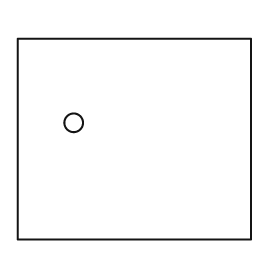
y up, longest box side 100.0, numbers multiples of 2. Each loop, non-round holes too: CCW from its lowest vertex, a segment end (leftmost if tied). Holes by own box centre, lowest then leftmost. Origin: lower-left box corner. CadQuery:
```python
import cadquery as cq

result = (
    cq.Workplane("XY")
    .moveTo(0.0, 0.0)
    .lineTo(100.0, 0.0)
    .lineTo(100.0, 86.0)
    .lineTo(0.0, 86.0)
    .close()
    .moveTo(24.0, 50.0)
    .circle(4.0)
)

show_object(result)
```